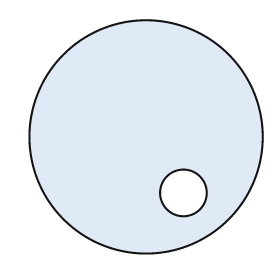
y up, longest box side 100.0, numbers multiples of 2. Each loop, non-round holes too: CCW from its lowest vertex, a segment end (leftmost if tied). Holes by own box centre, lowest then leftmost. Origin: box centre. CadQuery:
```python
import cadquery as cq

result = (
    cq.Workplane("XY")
    .moveTo(0.0, 0.0)
    .circle(50.0)
    .moveTo(16.0, -24.0)
    .circle(10.0)
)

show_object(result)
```